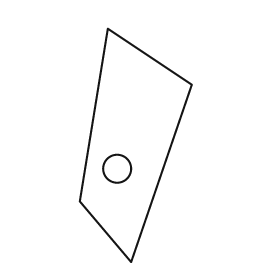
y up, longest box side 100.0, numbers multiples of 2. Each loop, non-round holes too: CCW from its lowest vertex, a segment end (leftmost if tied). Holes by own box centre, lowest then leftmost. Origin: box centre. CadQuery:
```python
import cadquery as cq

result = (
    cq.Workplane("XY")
    .moveTo(-2.0, -50.0)
    .lineTo(24.0, 26.0)
    .lineTo(-12.0, 50.0)
    .lineTo(-24.0, -24.0)
    .close()
    .moveTo(-8.0, -10.0)
    .circle(6.0)
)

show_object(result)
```